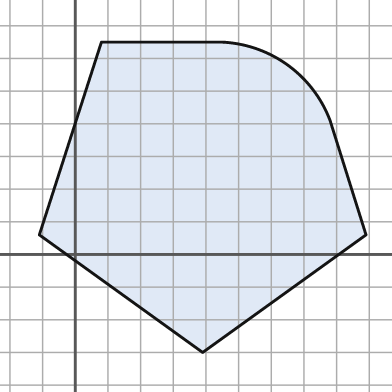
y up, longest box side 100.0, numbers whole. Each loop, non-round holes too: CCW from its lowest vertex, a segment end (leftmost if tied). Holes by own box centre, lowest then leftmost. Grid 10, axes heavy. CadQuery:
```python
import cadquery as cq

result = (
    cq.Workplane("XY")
    .moveTo(39.0, -30.0)
    .lineTo(89.0, 6.0)
    .lineTo(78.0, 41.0)
    .threePointArc((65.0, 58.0), (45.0, 65.0))
    .lineTo(8.0, 65.0)
    .lineTo(-11.0, 6.0)
    .close()
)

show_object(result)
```